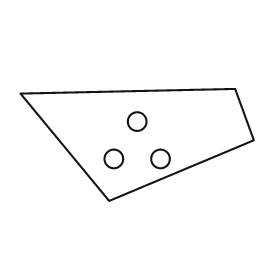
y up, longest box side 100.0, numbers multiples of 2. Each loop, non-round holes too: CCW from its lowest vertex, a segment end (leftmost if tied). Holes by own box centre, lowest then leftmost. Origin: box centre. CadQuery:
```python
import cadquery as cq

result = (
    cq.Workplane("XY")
    .moveTo(-12.0, -24.0)
    .lineTo(50.0, 2.0)
    .lineTo(42.0, 24.0)
    .lineTo(-50.0, 22.0)
    .close()
    .moveTo(-10.0, -6.0)
    .circle(4.0)
    .moveTo(10.0, -6.0)
    .circle(4.0)
    .moveTo(0.0, 10.0)
    .circle(4.0)
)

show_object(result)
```